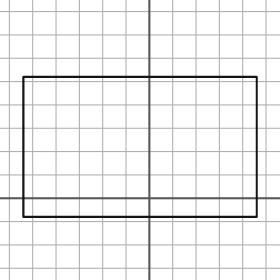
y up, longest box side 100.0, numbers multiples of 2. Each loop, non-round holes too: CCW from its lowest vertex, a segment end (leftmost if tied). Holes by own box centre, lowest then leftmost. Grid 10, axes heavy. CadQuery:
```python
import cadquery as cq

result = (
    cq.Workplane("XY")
    .moveTo(-54.0, -8.0)
    .lineTo(46.0, -8.0)
    .lineTo(46.0, 52.0)
    .lineTo(-54.0, 52.0)
    .close()
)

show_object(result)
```